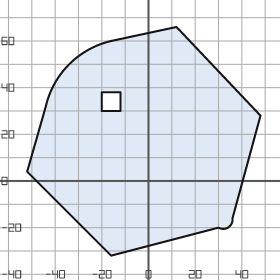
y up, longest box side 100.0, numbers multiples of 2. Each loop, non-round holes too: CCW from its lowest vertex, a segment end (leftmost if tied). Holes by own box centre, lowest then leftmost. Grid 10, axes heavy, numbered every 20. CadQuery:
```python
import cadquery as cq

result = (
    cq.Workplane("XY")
    .moveTo(-16.0, -32.0)
    .lineTo(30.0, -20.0)
    .threePointArc((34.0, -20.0), (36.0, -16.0))
    .lineTo(48.0, 28.0)
    .lineTo(12.0, 66.0)
    .lineTo(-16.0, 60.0)
    .threePointArc((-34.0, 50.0), (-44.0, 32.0))
    .lineTo(-52.0, 4.0)
    .close()
    .moveTo(-20.0, 30.0)
    .lineTo(-12.0, 30.0)
    .lineTo(-12.0, 38.0)
    .lineTo(-20.0, 38.0)
    .close()
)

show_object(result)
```